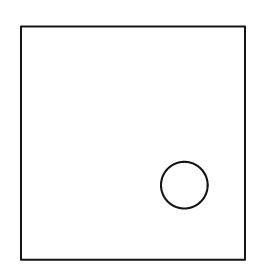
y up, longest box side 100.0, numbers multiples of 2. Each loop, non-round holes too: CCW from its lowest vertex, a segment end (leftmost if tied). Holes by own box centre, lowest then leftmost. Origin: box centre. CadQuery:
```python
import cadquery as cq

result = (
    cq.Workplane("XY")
    .moveTo(-48.0, -50.0)
    .lineTo(48.0, -50.0)
    .lineTo(48.0, 50.0)
    .lineTo(-48.0, 50.0)
    .close()
    .moveTo(22.0, -18.0)
    .circle(10.0)
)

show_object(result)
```